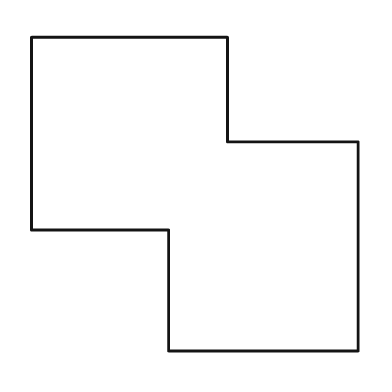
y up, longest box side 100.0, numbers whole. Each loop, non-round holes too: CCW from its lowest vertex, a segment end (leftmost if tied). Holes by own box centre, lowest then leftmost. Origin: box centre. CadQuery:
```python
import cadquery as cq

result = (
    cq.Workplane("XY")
    .moveTo(-8.0, -48.0)
    .lineTo(50.0, -48.0)
    .lineTo(50.0, 16.0)
    .lineTo(10.0, 16.0)
    .lineTo(10.0, 48.0)
    .lineTo(-50.0, 48.0)
    .lineTo(-50.0, -11.0)
    .lineTo(-8.0, -11.0)
    .close()
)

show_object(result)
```